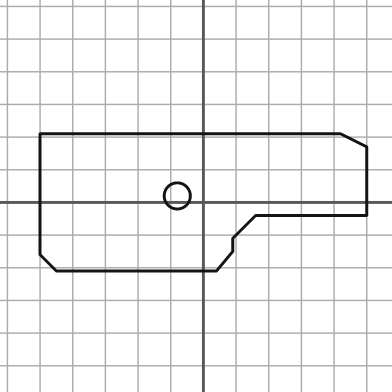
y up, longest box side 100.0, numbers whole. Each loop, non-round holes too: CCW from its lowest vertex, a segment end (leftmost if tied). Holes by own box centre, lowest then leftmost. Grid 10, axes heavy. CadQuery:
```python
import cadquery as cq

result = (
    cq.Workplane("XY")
    .moveTo(-45.0, -21.0)
    .lineTo(4.0, -21.0)
    .lineTo(9.0, -15.0)
    .lineTo(9.0, -11.0)
    .lineTo(16.0, -4.0)
    .lineTo(50.0, -4.0)
    .lineTo(50.0, 17.0)
    .lineTo(42.0, 21.0)
    .lineTo(-50.0, 21.0)
    .lineTo(-50.0, -16.0)
    .close()
    .moveTo(-8.0, 2.0)
    .circle(4.0)
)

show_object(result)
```